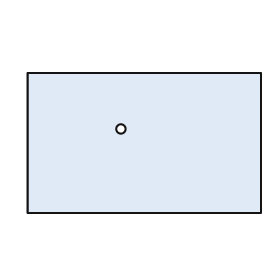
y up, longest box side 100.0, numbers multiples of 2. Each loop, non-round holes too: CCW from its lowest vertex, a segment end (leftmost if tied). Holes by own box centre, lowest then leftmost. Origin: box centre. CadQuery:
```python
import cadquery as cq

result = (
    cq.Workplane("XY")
    .moveTo(-50.0, -30.0)
    .lineTo(50.0, -30.0)
    .lineTo(50.0, 30.0)
    .lineTo(-50.0, 30.0)
    .close()
    .moveTo(-10.0, 6.0)
    .circle(2.0)
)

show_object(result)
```